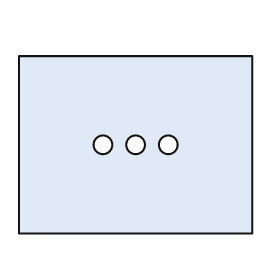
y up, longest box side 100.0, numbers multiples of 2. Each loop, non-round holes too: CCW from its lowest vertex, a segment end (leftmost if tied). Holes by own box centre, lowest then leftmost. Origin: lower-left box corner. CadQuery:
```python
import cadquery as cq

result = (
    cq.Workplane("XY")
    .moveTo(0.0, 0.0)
    .lineTo(100.0, 0.0)
    .lineTo(100.0, 76.0)
    .lineTo(0.0, 76.0)
    .close()
    .moveTo(36.0, 38.0)
    .circle(4.0)
    .moveTo(50.0, 38.0)
    .circle(4.0)
    .moveTo(64.0, 38.0)
    .circle(4.0)
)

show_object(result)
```